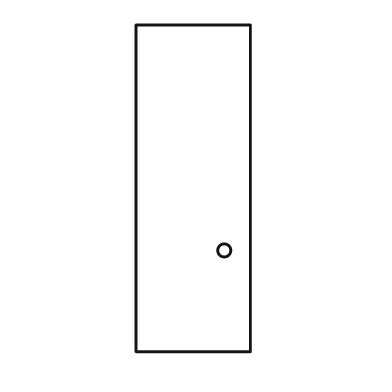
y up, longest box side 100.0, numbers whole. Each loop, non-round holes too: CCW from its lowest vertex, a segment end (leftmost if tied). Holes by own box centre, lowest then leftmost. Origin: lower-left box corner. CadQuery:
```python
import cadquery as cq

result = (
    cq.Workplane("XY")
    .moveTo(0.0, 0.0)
    .lineTo(35.0, 0.0)
    .lineTo(35.0, 100.0)
    .lineTo(0.0, 100.0)
    .close()
    .moveTo(27.0, 31.0)
    .circle(2.0)
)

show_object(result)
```